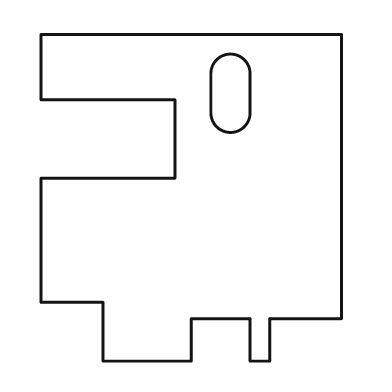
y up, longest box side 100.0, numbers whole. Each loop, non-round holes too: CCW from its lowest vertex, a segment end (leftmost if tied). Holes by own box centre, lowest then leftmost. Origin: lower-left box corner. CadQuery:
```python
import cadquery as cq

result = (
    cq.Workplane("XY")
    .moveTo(19.0, 0.0)
    .lineTo(46.0, 0.0)
    .lineTo(46.0, 13.0)
    .lineTo(64.0, 13.0)
    .lineTo(64.0, 0.0)
    .lineTo(70.0, 0.0)
    .lineTo(70.0, 13.0)
    .lineTo(92.0, 13.0)
    .lineTo(92.0, 100.0)
    .lineTo(0.0, 100.0)
    .lineTo(0.0, 80.0)
    .lineTo(41.0, 80.0)
    .lineTo(41.0, 56.0)
    .lineTo(0.0, 56.0)
    .lineTo(0.0, 18.0)
    .lineTo(19.0, 18.0)
    .close()
    .moveTo(52.0, 76.0)
    .threePointArc((58.0, 70.0), (64.0, 76.0))
    .lineTo(64.0, 88.0)
    .threePointArc((58.0, 94.0), (52.0, 88.0))
    .close()
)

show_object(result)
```